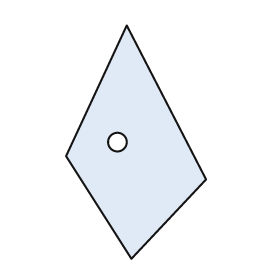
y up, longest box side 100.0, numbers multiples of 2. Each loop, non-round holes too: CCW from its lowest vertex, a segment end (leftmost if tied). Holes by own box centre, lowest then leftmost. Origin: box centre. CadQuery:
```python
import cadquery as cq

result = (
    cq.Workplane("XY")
    .moveTo(-2.0, -50.0)
    .lineTo(30.0, -16.0)
    .lineTo(-4.0, 50.0)
    .lineTo(-30.0, -6.0)
    .close()
    .moveTo(-8.0, 0.0)
    .circle(4.0)
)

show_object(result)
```